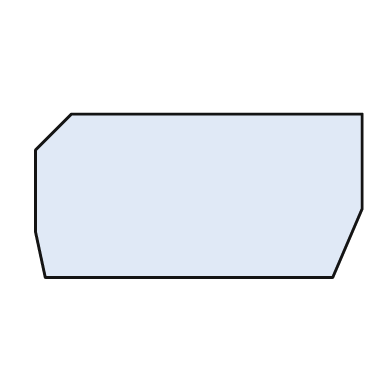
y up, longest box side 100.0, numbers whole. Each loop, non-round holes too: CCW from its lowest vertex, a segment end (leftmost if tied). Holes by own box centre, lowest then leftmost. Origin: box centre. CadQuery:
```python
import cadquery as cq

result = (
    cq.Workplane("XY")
    .moveTo(-47.0, -25.0)
    .lineTo(41.0, -25.0)
    .lineTo(50.0, -4.0)
    .lineTo(50.0, 25.0)
    .lineTo(-39.0, 25.0)
    .lineTo(-50.0, 14.0)
    .lineTo(-50.0, -11.0)
    .close()
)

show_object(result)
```